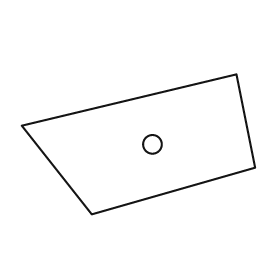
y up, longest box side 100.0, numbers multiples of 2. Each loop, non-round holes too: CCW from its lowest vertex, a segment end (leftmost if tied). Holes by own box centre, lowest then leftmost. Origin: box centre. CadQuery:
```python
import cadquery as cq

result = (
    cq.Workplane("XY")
    .moveTo(-20.0, -30.0)
    .lineTo(50.0, -10.0)
    .lineTo(42.0, 30.0)
    .lineTo(-50.0, 8.0)
    .close()
    .moveTo(6.0, 0.0)
    .circle(4.0)
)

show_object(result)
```